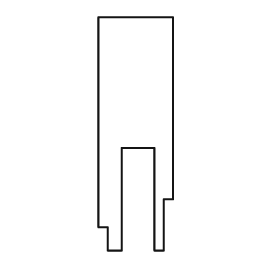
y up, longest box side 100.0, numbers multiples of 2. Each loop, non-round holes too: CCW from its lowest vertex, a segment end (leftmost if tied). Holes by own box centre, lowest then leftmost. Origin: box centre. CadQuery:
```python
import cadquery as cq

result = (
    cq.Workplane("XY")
    .moveTo(-12.0, -50.0)
    .lineTo(-6.0, -50.0)
    .lineTo(-6.0, -6.0)
    .lineTo(8.0, -6.0)
    .lineTo(8.0, -50.0)
    .lineTo(12.0, -50.0)
    .lineTo(12.0, -28.0)
    .lineTo(16.0, -28.0)
    .lineTo(16.0, 50.0)
    .lineTo(-16.0, 50.0)
    .lineTo(-16.0, -40.0)
    .lineTo(-12.0, -40.0)
    .close()
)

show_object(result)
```